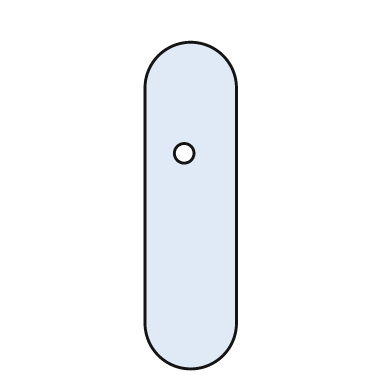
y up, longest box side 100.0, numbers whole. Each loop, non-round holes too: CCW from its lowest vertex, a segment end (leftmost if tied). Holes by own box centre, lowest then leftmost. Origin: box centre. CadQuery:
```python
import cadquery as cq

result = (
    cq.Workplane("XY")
    .moveTo(-14.0, -36.0)
    .threePointArc((0.0, -50.0), (14.0, -36.0))
    .lineTo(14.0, 36.0)
    .threePointArc((0.0, 50.0), (-14.0, 36.0))
    .close()
    .moveTo(-2.0, 16.0)
    .circle(3.0)
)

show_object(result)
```